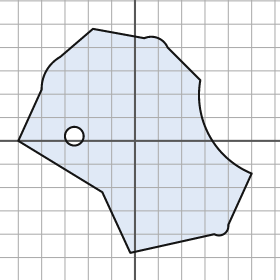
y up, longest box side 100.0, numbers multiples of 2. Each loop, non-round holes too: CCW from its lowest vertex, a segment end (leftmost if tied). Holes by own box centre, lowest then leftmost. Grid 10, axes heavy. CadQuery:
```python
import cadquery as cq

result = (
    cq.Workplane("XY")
    .moveTo(-2.0, -48.0)
    .lineTo(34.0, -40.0)
    .threePointArc((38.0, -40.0), (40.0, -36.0))
    .lineTo(50.0, -14.0)
    .threePointArc((32.0, 2.0), (28.0, 26.0))
    .lineTo(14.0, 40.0)
    .threePointArc((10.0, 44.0), (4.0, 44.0))
    .lineTo(-18.0, 48.0)
    .lineTo(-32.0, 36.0)
    .threePointArc((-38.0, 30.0), (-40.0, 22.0))
    .lineTo(-50.0, 0.0)
    .lineTo(-14.0, -22.0)
    .close()
    .moveTo(-26.0, 2.0)
    .circle(4.0)
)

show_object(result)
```